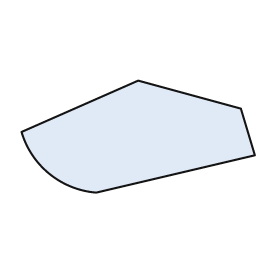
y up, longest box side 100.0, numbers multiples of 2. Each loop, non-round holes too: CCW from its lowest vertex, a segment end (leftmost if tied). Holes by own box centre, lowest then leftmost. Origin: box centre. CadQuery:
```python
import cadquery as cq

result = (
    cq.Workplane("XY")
    .moveTo(-18.0, -24.0)
    .lineTo(50.0, -8.0)
    .lineTo(44.0, 12.0)
    .lineTo(0.0, 24.0)
    .lineTo(-50.0, 2.0)
    .threePointArc((-38.0, -16.0), (-18.0, -24.0))
    .close()
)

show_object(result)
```